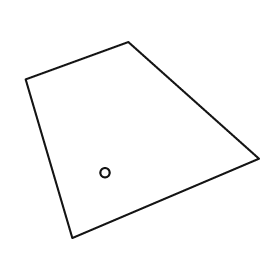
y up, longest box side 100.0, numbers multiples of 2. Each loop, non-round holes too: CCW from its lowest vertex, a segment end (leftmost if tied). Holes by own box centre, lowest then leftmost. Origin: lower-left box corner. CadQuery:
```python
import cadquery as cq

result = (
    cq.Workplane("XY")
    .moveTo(20.0, 0.0)
    .lineTo(100.0, 34.0)
    .lineTo(44.0, 84.0)
    .lineTo(0.0, 68.0)
    .close()
    .moveTo(34.0, 28.0)
    .circle(2.0)
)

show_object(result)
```